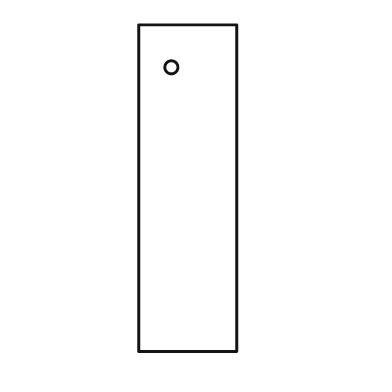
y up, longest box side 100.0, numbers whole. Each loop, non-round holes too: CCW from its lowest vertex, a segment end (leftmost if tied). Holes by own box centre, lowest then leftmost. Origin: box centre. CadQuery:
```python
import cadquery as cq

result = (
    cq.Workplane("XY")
    .moveTo(-15.0, -50.0)
    .lineTo(15.0, -50.0)
    .lineTo(15.0, 50.0)
    .lineTo(-15.0, 50.0)
    .close()
    .moveTo(-5.0, 37.0)
    .circle(2.0)
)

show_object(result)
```